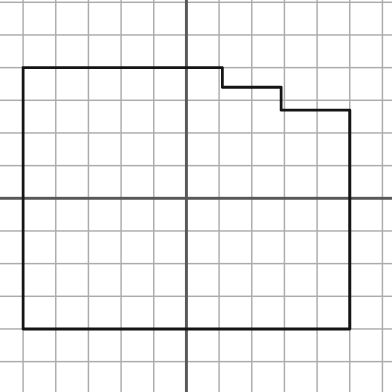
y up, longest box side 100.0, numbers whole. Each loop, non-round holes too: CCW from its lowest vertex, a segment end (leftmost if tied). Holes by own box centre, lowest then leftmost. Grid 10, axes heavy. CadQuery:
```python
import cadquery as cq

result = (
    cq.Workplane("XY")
    .moveTo(-50.0, -40.0)
    .lineTo(50.0, -40.0)
    .lineTo(50.0, 27.0)
    .lineTo(29.0, 27.0)
    .lineTo(29.0, 34.0)
    .lineTo(11.0, 34.0)
    .lineTo(11.0, 40.0)
    .lineTo(-50.0, 40.0)
    .close()
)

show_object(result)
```